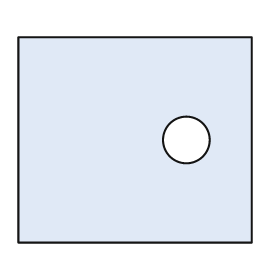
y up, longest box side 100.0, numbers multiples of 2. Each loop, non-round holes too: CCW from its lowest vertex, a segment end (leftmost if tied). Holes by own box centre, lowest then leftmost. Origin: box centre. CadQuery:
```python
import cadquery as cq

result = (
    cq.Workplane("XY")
    .moveTo(-50.0, -44.0)
    .lineTo(50.0, -44.0)
    .lineTo(50.0, 44.0)
    .lineTo(-50.0, 44.0)
    .close()
    .moveTo(22.0, 0.0)
    .circle(10.0)
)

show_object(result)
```